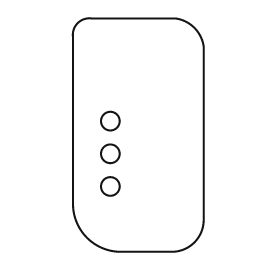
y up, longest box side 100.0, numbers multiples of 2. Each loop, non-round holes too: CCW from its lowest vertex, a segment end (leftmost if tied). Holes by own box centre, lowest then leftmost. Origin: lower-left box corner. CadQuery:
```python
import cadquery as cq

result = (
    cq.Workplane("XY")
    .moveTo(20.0, 0.0)
    .lineTo(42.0, 0.0)
    .threePointArc((52.0, 4.0), (56.0, 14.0))
    .lineTo(56.0, 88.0)
    .threePointArc((52.0, 96.0), (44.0, 100.0))
    .lineTo(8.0, 100.0)
    .threePointArc((2.0, 98.0), (0.0, 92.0))
    .lineTo(0.0, 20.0)
    .threePointArc((6.0, 6.0), (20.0, 0.0))
    .close()
    .moveTo(16.0, 28.0)
    .circle(4.0)
    .moveTo(16.0, 42.0)
    .circle(4.0)
    .moveTo(16.0, 56.0)
    .circle(4.0)
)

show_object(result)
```